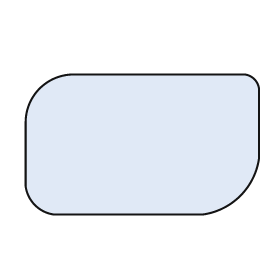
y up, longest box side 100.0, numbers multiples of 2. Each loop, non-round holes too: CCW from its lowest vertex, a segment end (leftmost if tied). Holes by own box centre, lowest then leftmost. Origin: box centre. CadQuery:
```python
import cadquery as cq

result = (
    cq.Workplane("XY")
    .moveTo(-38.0, -30.0)
    .lineTo(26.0, -30.0)
    .threePointArc((42.0, -22.0), (50.0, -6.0))
    .lineTo(50.0, 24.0)
    .threePointArc((48.0, 28.0), (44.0, 30.0))
    .lineTo(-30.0, 30.0)
    .threePointArc((-44.0, 24.0), (-50.0, 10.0))
    .lineTo(-50.0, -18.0)
    .threePointArc((-46.0, -26.0), (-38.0, -30.0))
    .close()
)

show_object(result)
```